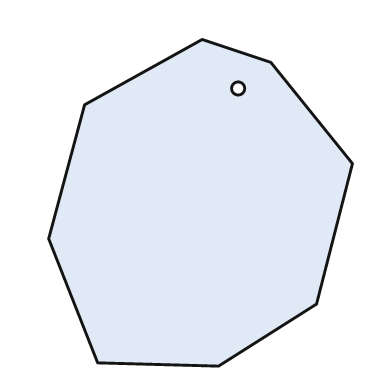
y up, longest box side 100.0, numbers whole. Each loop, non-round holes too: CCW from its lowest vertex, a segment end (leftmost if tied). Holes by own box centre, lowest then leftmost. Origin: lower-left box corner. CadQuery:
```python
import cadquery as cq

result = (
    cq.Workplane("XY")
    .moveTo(52.0, 0.0)
    .lineTo(82.0, 19.0)
    .lineTo(93.0, 62.0)
    .lineTo(68.0, 93.0)
    .lineTo(47.0, 100.0)
    .lineTo(11.0, 80.0)
    .lineTo(0.0, 39.0)
    .lineTo(15.0, 1.0)
    .close()
    .moveTo(58.0, 85.0)
    .circle(2.0)
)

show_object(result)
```